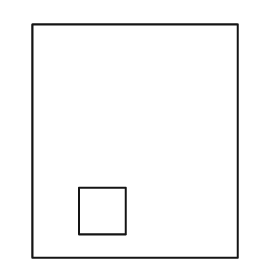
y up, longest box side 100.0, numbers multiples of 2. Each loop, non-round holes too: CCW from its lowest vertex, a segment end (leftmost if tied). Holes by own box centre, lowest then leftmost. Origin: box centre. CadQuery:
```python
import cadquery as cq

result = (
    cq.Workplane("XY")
    .moveTo(-44.0, -50.0)
    .lineTo(44.0, -50.0)
    .lineTo(44.0, 50.0)
    .lineTo(-44.0, 50.0)
    .close()
    .moveTo(-24.0, -40.0)
    .lineTo(-4.0, -40.0)
    .lineTo(-4.0, -20.0)
    .lineTo(-24.0, -20.0)
    .close()
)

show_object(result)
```